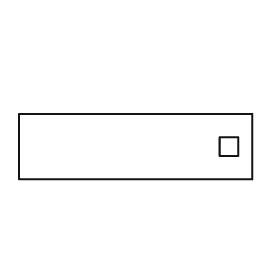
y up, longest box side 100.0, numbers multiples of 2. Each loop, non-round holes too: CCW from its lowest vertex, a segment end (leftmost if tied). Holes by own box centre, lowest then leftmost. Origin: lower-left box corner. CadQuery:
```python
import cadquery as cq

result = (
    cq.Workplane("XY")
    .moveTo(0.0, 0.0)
    .lineTo(100.0, 0.0)
    .lineTo(100.0, 28.0)
    .lineTo(0.0, 28.0)
    .close()
    .moveTo(86.0, 10.0)
    .lineTo(94.0, 10.0)
    .lineTo(94.0, 18.0)
    .lineTo(86.0, 18.0)
    .close()
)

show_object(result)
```